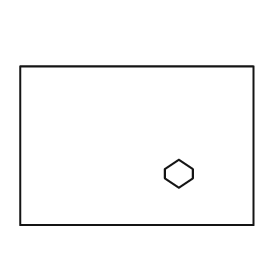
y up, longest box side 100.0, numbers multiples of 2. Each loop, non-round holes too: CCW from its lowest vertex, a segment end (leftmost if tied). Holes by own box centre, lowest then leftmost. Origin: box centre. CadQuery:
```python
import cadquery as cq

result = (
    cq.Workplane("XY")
    .moveTo(-50.0, -34.0)
    .lineTo(50.0, -34.0)
    .lineTo(50.0, 34.0)
    .lineTo(-50.0, 34.0)
    .close()
    .moveTo(18.0, -18.0)
    .lineTo(24.0, -14.0)
    .lineTo(24.0, -10.0)
    .lineTo(18.0, -6.0)
    .lineTo(12.0, -10.0)
    .lineTo(12.0, -14.0)
    .close()
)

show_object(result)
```